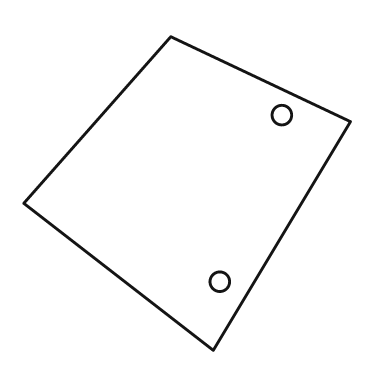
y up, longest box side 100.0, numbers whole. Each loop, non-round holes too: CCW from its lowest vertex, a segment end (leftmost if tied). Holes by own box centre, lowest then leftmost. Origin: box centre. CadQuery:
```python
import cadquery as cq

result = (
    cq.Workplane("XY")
    .moveTo(8.0, -48.0)
    .lineTo(50.0, 22.0)
    .lineTo(-5.0, 48.0)
    .lineTo(-50.0, -3.0)
    .close()
    .moveTo(10.0, -27.0)
    .circle(3.0)
    .moveTo(29.0, 24.0)
    .circle(3.0)
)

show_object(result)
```